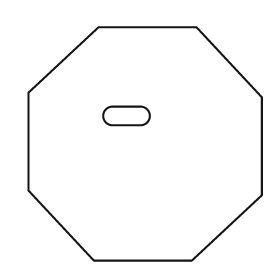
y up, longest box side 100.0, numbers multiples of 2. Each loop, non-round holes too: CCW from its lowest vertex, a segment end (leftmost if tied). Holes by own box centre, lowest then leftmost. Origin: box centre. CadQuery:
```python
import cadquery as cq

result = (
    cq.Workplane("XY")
    .moveTo(-22.0, -50.0)
    .lineTo(20.0, -50.0)
    .lineTo(50.0, -22.0)
    .lineTo(50.0, 20.0)
    .lineTo(22.0, 50.0)
    .lineTo(-20.0, 50.0)
    .lineTo(-50.0, 22.0)
    .lineTo(-50.0, -20.0)
    .close()
    .moveTo(-14.0, 8.0)
    .lineTo(-2.0, 8.0)
    .threePointArc((2.0, 12.0), (-2.0, 16.0))
    .lineTo(-14.0, 16.0)
    .threePointArc((-18.0, 12.0), (-14.0, 8.0))
    .close()
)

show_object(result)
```